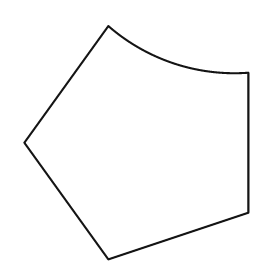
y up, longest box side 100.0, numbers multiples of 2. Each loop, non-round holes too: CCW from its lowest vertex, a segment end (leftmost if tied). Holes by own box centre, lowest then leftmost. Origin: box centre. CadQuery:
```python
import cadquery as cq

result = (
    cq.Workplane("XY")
    .moveTo(-12.0, -50.0)
    .lineTo(48.0, -30.0)
    .lineTo(48.0, 30.0)
    .threePointArc((16.0, 34.0), (-12.0, 50.0))
    .lineTo(-48.0, 0.0)
    .close()
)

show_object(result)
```